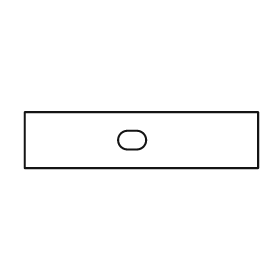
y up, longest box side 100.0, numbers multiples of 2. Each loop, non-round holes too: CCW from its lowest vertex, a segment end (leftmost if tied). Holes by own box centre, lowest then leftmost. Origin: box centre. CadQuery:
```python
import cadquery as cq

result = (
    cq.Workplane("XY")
    .moveTo(-50.0, -12.0)
    .lineTo(50.0, -12.0)
    .lineTo(50.0, 12.0)
    .lineTo(-50.0, 12.0)
    .close()
    .moveTo(-6.0, -4.0)
    .lineTo(-2.0, -4.0)
    .threePointArc((2.0, 0.0), (-2.0, 4.0))
    .lineTo(-6.0, 4.0)
    .threePointArc((-10.0, 0.0), (-6.0, -4.0))
    .close()
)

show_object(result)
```